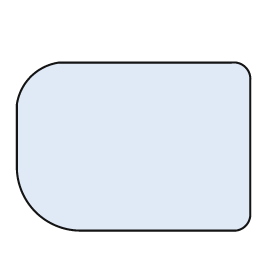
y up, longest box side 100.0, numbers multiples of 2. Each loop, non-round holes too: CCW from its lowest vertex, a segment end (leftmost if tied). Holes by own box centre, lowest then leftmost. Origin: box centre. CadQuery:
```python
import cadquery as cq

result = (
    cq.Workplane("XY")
    .moveTo(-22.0, -36.0)
    .lineTo(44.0, -36.0)
    .threePointArc((48.0, -34.0), (50.0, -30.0))
    .lineTo(50.0, 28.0)
    .threePointArc((48.0, 34.0), (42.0, 36.0))
    .lineTo(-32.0, 36.0)
    .threePointArc((-44.0, 30.0), (-50.0, 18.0))
    .lineTo(-50.0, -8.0)
    .threePointArc((-42.0, -28.0), (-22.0, -36.0))
    .close()
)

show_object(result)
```